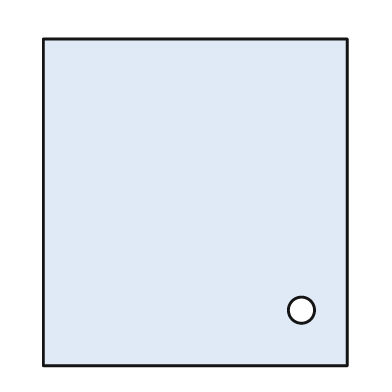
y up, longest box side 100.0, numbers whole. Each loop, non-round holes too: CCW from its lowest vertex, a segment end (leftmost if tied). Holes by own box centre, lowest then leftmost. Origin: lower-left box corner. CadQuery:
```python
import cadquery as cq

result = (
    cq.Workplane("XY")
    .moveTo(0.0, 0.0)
    .lineTo(93.0, 0.0)
    .lineTo(93.0, 100.0)
    .lineTo(0.0, 100.0)
    .close()
    .moveTo(79.0, 17.0)
    .circle(4.0)
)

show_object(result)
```